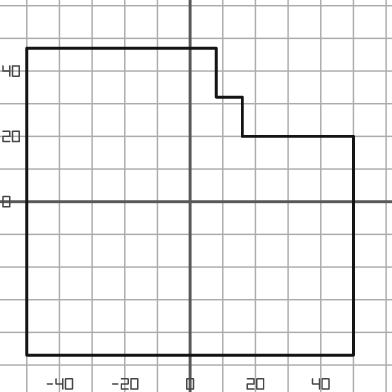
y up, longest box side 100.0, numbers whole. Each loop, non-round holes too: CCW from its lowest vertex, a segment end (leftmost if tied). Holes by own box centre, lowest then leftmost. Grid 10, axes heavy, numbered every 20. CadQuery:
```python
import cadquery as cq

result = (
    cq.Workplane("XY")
    .moveTo(-50.0, -47.0)
    .lineTo(50.0, -47.0)
    .lineTo(50.0, 20.0)
    .lineTo(16.0, 20.0)
    .lineTo(16.0, 32.0)
    .lineTo(8.0, 32.0)
    .lineTo(8.0, 47.0)
    .lineTo(-50.0, 47.0)
    .close()
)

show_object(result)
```